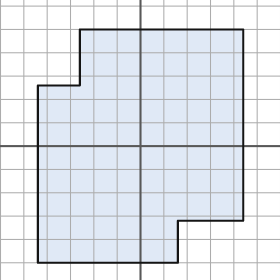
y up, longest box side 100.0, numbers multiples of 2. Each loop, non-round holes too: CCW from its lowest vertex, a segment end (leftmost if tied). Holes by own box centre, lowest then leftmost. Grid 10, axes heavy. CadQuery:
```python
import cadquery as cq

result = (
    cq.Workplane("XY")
    .moveTo(-44.0, -50.0)
    .lineTo(16.0, -50.0)
    .lineTo(16.0, -32.0)
    .lineTo(44.0, -32.0)
    .lineTo(44.0, 50.0)
    .lineTo(-26.0, 50.0)
    .lineTo(-26.0, 26.0)
    .lineTo(-44.0, 26.0)
    .close()
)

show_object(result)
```